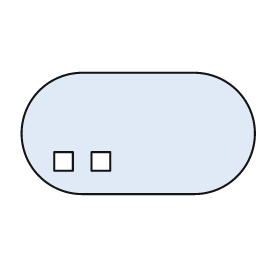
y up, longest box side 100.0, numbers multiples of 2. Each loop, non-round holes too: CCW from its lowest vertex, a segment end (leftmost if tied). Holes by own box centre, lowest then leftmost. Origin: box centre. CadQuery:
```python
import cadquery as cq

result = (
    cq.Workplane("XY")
    .moveTo(-24.0, -26.0)
    .lineTo(24.0, -26.0)
    .threePointArc((50.0, 0.0), (24.0, 26.0))
    .lineTo(-24.0, 26.0)
    .threePointArc((-50.0, 0.0), (-24.0, -26.0))
    .close()
    .moveTo(-36.0, -16.0)
    .lineTo(-28.0, -16.0)
    .lineTo(-28.0, -8.0)
    .lineTo(-36.0, -8.0)
    .close()
    .moveTo(-20.0, -16.0)
    .lineTo(-12.0, -16.0)
    .lineTo(-12.0, -8.0)
    .lineTo(-20.0, -8.0)
    .close()
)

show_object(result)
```